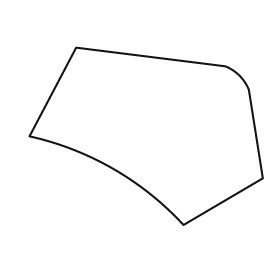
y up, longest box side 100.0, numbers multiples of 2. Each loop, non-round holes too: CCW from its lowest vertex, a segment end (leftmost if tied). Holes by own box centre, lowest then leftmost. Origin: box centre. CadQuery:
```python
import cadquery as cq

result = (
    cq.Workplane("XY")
    .moveTo(16.0, -38.0)
    .lineTo(50.0, -18.0)
    .lineTo(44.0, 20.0)
    .threePointArc((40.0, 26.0), (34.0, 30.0))
    .lineTo(-30.0, 38.0)
    .lineTo(-50.0, 0.0)
    .threePointArc((-14.0, -14.0), (16.0, -38.0))
    .close()
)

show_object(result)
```